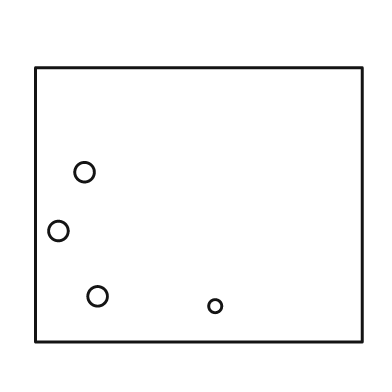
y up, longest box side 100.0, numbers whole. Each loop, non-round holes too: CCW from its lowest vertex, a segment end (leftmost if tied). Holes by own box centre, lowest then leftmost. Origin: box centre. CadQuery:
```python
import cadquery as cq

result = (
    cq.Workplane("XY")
    .moveTo(-50.0, -42.0)
    .lineTo(50.0, -42.0)
    .lineTo(50.0, 42.0)
    .lineTo(-50.0, 42.0)
    .close()
    .moveTo(5.0, -31.0)
    .circle(2.0)
    .moveTo(-31.0, -28.0)
    .circle(3.0)
    .moveTo(-43.0, -8.0)
    .circle(3.0)
    .moveTo(-35.0, 10.0)
    .circle(3.0)
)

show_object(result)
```